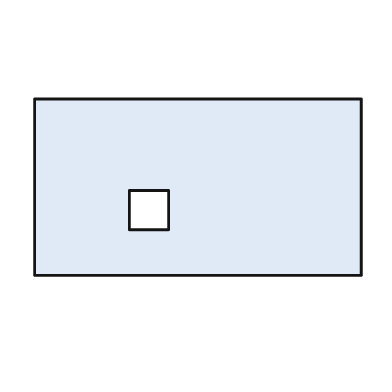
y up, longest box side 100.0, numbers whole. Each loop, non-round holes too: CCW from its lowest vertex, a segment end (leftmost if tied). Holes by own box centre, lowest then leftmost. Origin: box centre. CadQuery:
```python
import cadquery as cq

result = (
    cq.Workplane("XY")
    .moveTo(-50.0, -27.0)
    .lineTo(50.0, -27.0)
    .lineTo(50.0, 27.0)
    .lineTo(-50.0, 27.0)
    .close()
    .moveTo(-21.0, -13.0)
    .lineTo(-9.0, -13.0)
    .lineTo(-9.0, -1.0)
    .lineTo(-21.0, -1.0)
    .close()
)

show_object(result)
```